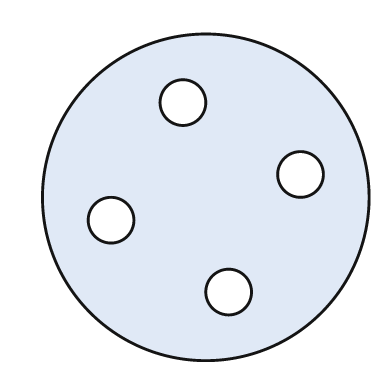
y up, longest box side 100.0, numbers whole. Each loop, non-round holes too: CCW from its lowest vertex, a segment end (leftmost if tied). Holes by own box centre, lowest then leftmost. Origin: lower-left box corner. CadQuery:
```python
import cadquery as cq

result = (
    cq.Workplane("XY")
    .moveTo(50.0, 50.0)
    .circle(50.0)
    .moveTo(57.0, 21.0)
    .circle(7.0)
    .moveTo(21.0, 43.0)
    .circle(7.0)
    .moveTo(79.0, 57.0)
    .circle(7.0)
    .moveTo(43.0, 79.0)
    .circle(7.0)
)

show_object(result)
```